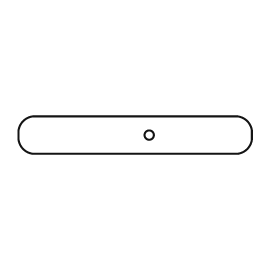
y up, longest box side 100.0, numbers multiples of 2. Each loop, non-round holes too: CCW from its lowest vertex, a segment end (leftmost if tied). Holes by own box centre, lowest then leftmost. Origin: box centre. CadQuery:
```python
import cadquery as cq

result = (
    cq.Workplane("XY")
    .moveTo(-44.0, -8.0)
    .lineTo(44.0, -8.0)
    .threePointArc((48.0, -6.0), (50.0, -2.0))
    .lineTo(50.0, 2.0)
    .threePointArc((48.0, 6.0), (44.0, 8.0))
    .lineTo(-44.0, 8.0)
    .threePointArc((-48.0, 6.0), (-50.0, 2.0))
    .lineTo(-50.0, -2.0)
    .threePointArc((-48.0, -6.0), (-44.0, -8.0))
    .close()
    .moveTo(6.0, 0.0)
    .circle(2.0)
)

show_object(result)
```